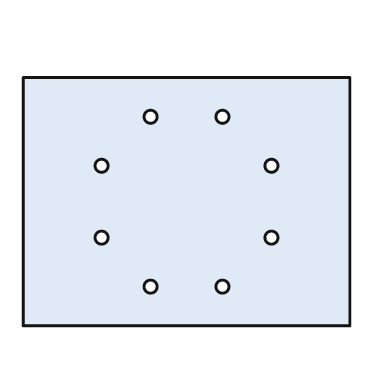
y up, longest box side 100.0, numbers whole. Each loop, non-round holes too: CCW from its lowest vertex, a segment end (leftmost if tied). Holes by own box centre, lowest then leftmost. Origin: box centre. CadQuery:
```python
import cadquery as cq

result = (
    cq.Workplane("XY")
    .moveTo(-50.0, -38.0)
    .lineTo(50.0, -38.0)
    .lineTo(50.0, 38.0)
    .lineTo(-50.0, 38.0)
    .close()
    .moveTo(-11.0, -26.0)
    .circle(2.0)
    .moveTo(11.0, -26.0)
    .circle(2.0)
    .moveTo(-26.0, -11.0)
    .circle(2.0)
    .moveTo(26.0, -11.0)
    .circle(2.0)
    .moveTo(-26.0, 11.0)
    .circle(2.0)
    .moveTo(26.0, 11.0)
    .circle(2.0)
    .moveTo(-11.0, 26.0)
    .circle(2.0)
    .moveTo(11.0, 26.0)
    .circle(2.0)
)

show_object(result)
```